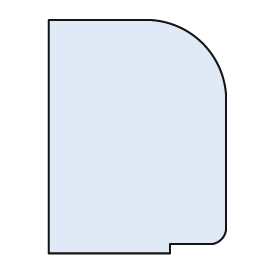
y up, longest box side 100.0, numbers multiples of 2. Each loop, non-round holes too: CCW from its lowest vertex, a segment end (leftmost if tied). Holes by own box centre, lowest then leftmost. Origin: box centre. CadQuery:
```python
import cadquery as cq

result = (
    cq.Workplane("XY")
    .moveTo(-38.0, -50.0)
    .lineTo(14.0, -50.0)
    .lineTo(14.0, -46.0)
    .lineTo(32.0, -46.0)
    .threePointArc((36.0, -44.0), (38.0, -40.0))
    .lineTo(38.0, 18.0)
    .threePointArc((28.0, 40.0), (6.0, 50.0))
    .lineTo(-38.0, 50.0)
    .close()
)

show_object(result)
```